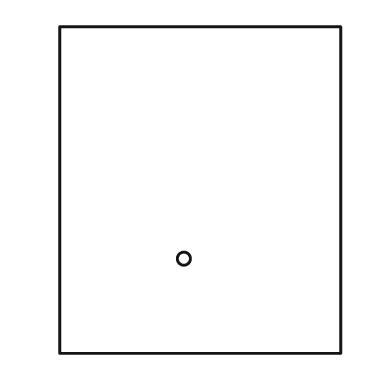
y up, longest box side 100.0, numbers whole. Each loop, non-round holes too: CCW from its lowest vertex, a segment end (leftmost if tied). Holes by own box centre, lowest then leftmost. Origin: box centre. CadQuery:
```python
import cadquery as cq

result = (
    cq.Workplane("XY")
    .moveTo(-43.0, -50.0)
    .lineTo(43.0, -50.0)
    .lineTo(43.0, 50.0)
    .lineTo(-43.0, 50.0)
    .close()
    .moveTo(-5.0, -21.0)
    .circle(2.0)
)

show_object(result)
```